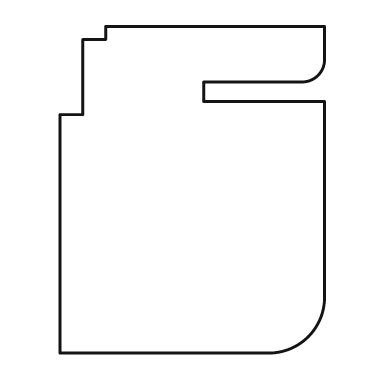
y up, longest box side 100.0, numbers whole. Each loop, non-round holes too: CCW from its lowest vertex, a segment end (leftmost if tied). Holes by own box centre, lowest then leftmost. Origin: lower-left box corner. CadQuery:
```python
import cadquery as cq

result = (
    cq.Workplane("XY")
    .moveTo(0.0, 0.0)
    .lineTo(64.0, 0.0)
    .threePointArc((76.0, 5.0), (81.0, 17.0))
    .lineTo(81.0, 77.0)
    .lineTo(44.0, 77.0)
    .lineTo(44.0, 83.0)
    .lineTo(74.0, 83.0)
    .threePointArc((79.0, 85.0), (81.0, 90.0))
    .lineTo(81.0, 100.0)
    .lineTo(14.0, 100.0)
    .lineTo(14.0, 96.0)
    .lineTo(7.0, 96.0)
    .lineTo(7.0, 73.0)
    .lineTo(0.0, 73.0)
    .close()
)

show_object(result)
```